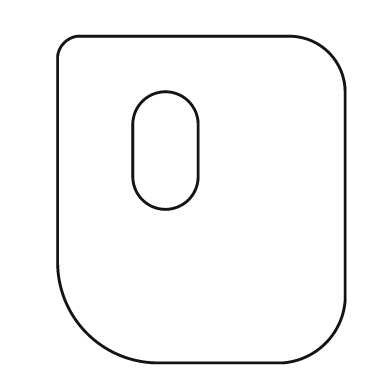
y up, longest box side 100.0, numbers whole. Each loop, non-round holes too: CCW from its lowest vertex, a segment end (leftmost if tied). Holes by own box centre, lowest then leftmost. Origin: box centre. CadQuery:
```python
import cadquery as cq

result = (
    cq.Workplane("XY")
    .moveTo(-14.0, -50.0)
    .lineTo(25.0, -50.0)
    .threePointArc((38.0, -44.0), (44.0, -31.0))
    .lineTo(44.0, 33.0)
    .threePointArc((39.0, 45.0), (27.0, 50.0))
    .lineTo(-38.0, 50.0)
    .threePointArc((-42.0, 48.0), (-44.0, 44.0))
    .lineTo(-44.0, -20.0)
    .threePointArc((-35.0, -41.0), (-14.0, -50.0))
    .close()
    .moveTo(-21.0, 7.0)
    .threePointArc((-11.0, -3.0), (-1.0, 7.0))
    .lineTo(-1.0, 23.0)
    .threePointArc((-11.0, 33.0), (-21.0, 23.0))
    .close()
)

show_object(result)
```